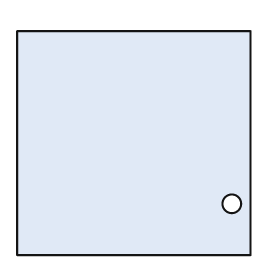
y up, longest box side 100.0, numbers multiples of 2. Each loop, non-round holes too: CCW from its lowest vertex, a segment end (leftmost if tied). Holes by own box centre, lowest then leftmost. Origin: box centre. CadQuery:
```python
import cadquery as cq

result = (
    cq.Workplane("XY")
    .moveTo(-50.0, -48.0)
    .lineTo(50.0, -48.0)
    .lineTo(50.0, 48.0)
    .lineTo(-50.0, 48.0)
    .close()
    .moveTo(42.0, -26.0)
    .circle(4.0)
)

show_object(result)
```